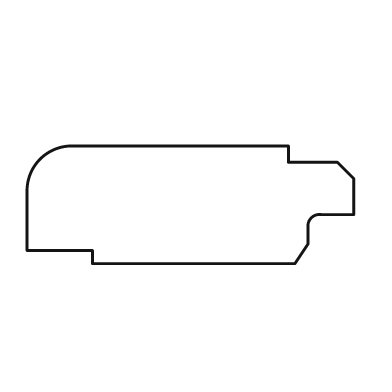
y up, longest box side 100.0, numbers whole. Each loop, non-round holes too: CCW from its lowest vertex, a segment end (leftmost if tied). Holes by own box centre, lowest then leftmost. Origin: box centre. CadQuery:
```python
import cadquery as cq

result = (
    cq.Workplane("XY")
    .moveTo(-30.0, -18.0)
    .lineTo(32.0, -18.0)
    .lineTo(36.0, -12.0)
    .lineTo(36.0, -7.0)
    .threePointArc((37.0, -4.0), (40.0, -3.0))
    .lineTo(50.0, -3.0)
    .lineTo(50.0, 8.0)
    .lineTo(45.0, 13.0)
    .lineTo(30.0, 13.0)
    .lineTo(30.0, 18.0)
    .lineTo(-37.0, 18.0)
    .threePointArc((-46.0, 14.0), (-50.0, 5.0))
    .lineTo(-50.0, -14.0)
    .lineTo(-30.0, -14.0)
    .close()
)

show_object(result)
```